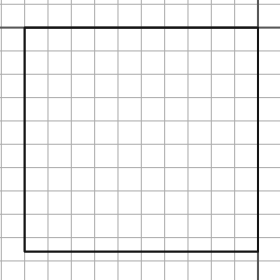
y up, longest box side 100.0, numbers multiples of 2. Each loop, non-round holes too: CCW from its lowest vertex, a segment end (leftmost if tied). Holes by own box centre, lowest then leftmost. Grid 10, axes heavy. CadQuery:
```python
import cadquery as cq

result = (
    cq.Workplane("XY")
    .moveTo(-100.0, -96.0)
    .lineTo(0.0, -96.0)
    .lineTo(0.0, 0.0)
    .lineTo(-100.0, 0.0)
    .close()
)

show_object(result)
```